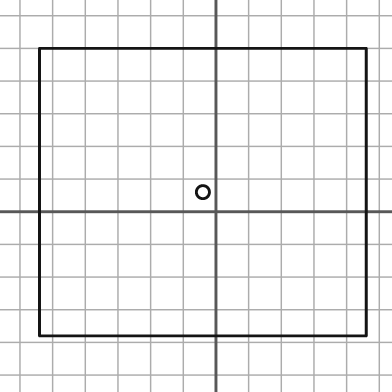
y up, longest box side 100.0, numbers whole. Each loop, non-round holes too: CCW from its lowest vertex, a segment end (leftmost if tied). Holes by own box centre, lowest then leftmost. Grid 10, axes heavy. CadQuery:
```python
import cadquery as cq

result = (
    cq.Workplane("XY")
    .moveTo(-54.0, -38.0)
    .lineTo(46.0, -38.0)
    .lineTo(46.0, 50.0)
    .lineTo(-54.0, 50.0)
    .close()
    .moveTo(-4.0, 6.0)
    .circle(2.0)
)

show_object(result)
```